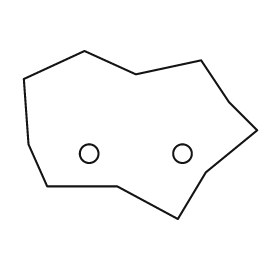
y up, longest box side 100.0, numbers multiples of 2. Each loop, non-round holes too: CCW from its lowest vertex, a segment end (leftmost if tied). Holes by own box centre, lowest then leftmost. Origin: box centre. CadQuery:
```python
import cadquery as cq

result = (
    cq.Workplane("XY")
    .moveTo(16.0, -36.0)
    .lineTo(28.0, -16.0)
    .lineTo(50.0, 2.0)
    .lineTo(38.0, 14.0)
    .lineTo(26.0, 32.0)
    .lineTo(-2.0, 26.0)
    .lineTo(-24.0, 36.0)
    .lineTo(-50.0, 24.0)
    .lineTo(-48.0, -4.0)
    .lineTo(-40.0, -22.0)
    .lineTo(-10.0, -22.0)
    .close()
    .moveTo(-22.0, -8.0)
    .circle(4.0)
    .moveTo(18.0, -8.0)
    .circle(4.0)
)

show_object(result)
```